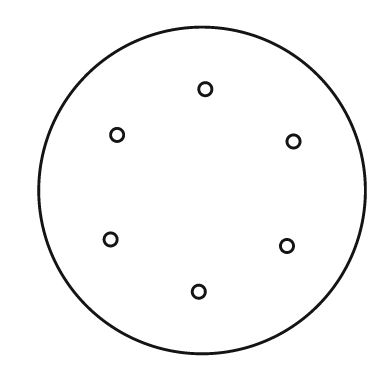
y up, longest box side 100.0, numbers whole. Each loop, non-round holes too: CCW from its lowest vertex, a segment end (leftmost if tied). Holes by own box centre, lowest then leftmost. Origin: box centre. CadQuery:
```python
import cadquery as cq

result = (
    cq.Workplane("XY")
    .moveTo(0.0, 0.0)
    .circle(50.0)
    .moveTo(-1.0, -31.0)
    .circle(2.0)
    .moveTo(26.0, -17.0)
    .circle(2.0)
    .moveTo(-28.0, -15.0)
    .circle(2.0)
    .moveTo(28.0, 15.0)
    .circle(2.0)
    .moveTo(-26.0, 17.0)
    .circle(2.0)
    .moveTo(1.0, 31.0)
    .circle(2.0)
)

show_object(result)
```